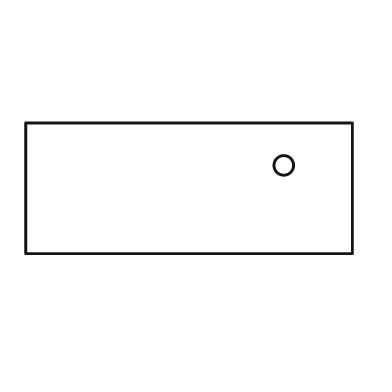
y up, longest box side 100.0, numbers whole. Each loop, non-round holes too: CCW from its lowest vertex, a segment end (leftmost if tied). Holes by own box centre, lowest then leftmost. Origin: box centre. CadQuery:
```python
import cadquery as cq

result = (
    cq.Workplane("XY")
    .moveTo(-50.0, -20.0)
    .lineTo(50.0, -20.0)
    .lineTo(50.0, 20.0)
    .lineTo(-50.0, 20.0)
    .close()
    .moveTo(29.0, 7.0)
    .circle(3.0)
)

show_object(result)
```